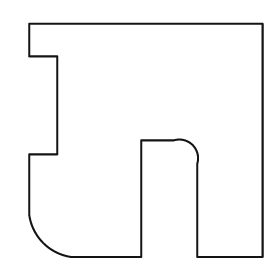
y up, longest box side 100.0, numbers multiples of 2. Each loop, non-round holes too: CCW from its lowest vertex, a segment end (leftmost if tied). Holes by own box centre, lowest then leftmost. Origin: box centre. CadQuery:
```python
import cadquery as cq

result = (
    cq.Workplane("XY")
    .moveTo(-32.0, -50.0)
    .lineTo(-2.0, -50.0)
    .lineTo(-2.0, 0.0)
    .lineTo(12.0, 0.0)
    .threePointArc((20.0, -2.0), (22.0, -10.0))
    .lineTo(22.0, -50.0)
    .lineTo(50.0, -50.0)
    .lineTo(50.0, 50.0)
    .lineTo(-50.0, 50.0)
    .lineTo(-50.0, 36.0)
    .lineTo(-38.0, 36.0)
    .lineTo(-38.0, -6.0)
    .lineTo(-50.0, -6.0)
    .lineTo(-50.0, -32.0)
    .threePointArc((-44.0, -44.0), (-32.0, -50.0))
    .close()
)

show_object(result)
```